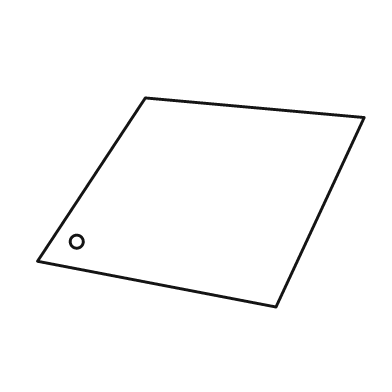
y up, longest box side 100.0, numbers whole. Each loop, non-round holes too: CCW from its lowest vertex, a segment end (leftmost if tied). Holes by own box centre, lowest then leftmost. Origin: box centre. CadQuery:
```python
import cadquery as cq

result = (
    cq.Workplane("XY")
    .moveTo(23.0, -32.0)
    .lineTo(50.0, 26.0)
    .lineTo(-17.0, 32.0)
    .lineTo(-50.0, -18.0)
    .close()
    .moveTo(-38.0, -12.0)
    .circle(2.0)
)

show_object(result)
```